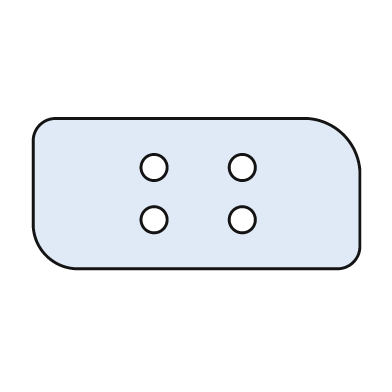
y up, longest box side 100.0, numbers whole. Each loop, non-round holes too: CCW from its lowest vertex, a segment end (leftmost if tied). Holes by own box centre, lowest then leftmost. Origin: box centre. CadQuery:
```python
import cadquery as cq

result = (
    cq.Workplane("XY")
    .moveTo(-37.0, -23.0)
    .lineTo(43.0, -23.0)
    .threePointArc((48.0, -21.0), (50.0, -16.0))
    .lineTo(50.0, 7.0)
    .threePointArc((45.0, 18.0), (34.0, 23.0))
    .lineTo(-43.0, 23.0)
    .threePointArc((-48.0, 21.0), (-50.0, 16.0))
    .lineTo(-50.0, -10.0)
    .threePointArc((-46.0, -19.0), (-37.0, -23.0))
    .close()
    .moveTo(-13.0, -8.0)
    .circle(4.0)
    .moveTo(14.0, -8.0)
    .circle(4.0)
    .moveTo(-13.0, 8.0)
    .circle(4.0)
    .moveTo(14.0, 8.0)
    .circle(4.0)
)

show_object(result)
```